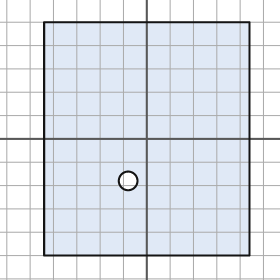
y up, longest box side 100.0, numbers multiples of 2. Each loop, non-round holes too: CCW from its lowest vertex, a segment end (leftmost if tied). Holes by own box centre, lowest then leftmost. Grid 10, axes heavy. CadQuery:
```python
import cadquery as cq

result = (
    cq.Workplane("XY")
    .moveTo(-44.0, -50.0)
    .lineTo(44.0, -50.0)
    .lineTo(44.0, 50.0)
    .lineTo(-44.0, 50.0)
    .close()
    .moveTo(-8.0, -18.0)
    .circle(4.0)
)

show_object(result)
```